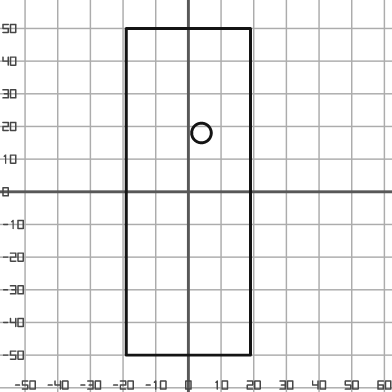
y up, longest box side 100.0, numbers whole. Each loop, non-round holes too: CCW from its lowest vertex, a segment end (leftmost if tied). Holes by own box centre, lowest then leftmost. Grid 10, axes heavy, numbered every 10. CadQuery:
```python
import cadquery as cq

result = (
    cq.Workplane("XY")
    .moveTo(-19.0, -50.0)
    .lineTo(19.0, -50.0)
    .lineTo(19.0, 50.0)
    .lineTo(-19.0, 50.0)
    .close()
    .moveTo(4.0, 18.0)
    .circle(3.0)
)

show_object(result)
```